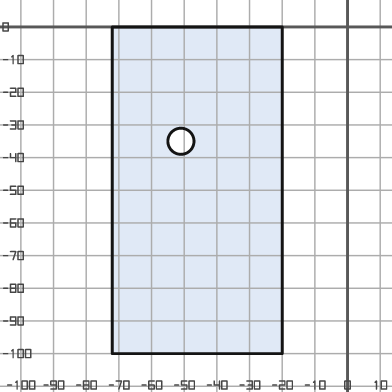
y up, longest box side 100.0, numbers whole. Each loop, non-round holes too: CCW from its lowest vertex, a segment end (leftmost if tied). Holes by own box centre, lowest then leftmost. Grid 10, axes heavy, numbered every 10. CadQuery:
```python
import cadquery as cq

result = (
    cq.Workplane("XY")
    .moveTo(-72.0, -100.0)
    .lineTo(-20.0, -100.0)
    .lineTo(-20.0, 0.0)
    .lineTo(-72.0, 0.0)
    .close()
    .moveTo(-51.0, -35.0)
    .circle(4.0)
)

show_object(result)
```